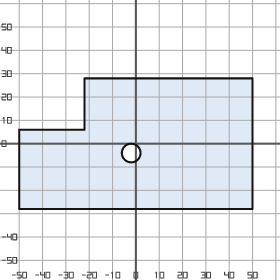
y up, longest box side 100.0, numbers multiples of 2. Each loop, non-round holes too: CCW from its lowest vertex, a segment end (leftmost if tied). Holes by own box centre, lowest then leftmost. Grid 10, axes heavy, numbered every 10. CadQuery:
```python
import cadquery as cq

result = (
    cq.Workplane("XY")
    .moveTo(-50.0, -28.0)
    .lineTo(50.0, -28.0)
    .lineTo(50.0, 28.0)
    .lineTo(-22.0, 28.0)
    .lineTo(-22.0, 6.0)
    .lineTo(-50.0, 6.0)
    .close()
    .moveTo(-2.0, -4.0)
    .circle(4.0)
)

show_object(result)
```